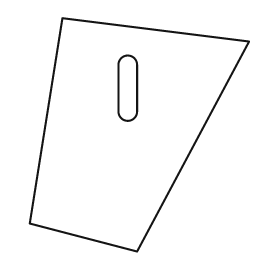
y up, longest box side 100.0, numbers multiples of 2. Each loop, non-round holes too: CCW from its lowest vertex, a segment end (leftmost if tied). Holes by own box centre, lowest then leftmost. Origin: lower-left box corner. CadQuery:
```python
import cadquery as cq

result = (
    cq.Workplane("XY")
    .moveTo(46.0, 0.0)
    .lineTo(94.0, 90.0)
    .lineTo(14.0, 100.0)
    .lineTo(0.0, 12.0)
    .close()
    .moveTo(38.0, 60.0)
    .threePointArc((42.0, 56.0), (46.0, 60.0))
    .lineTo(46.0, 80.0)
    .threePointArc((42.0, 84.0), (38.0, 80.0))
    .close()
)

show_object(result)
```